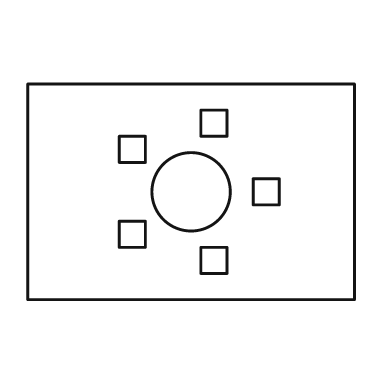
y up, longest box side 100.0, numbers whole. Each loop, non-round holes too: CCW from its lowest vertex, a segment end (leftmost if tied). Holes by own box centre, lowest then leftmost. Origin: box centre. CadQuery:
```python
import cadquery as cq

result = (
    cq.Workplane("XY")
    .moveTo(-50.0, -33.0)
    .lineTo(50.0, -33.0)
    .lineTo(50.0, 33.0)
    .lineTo(-50.0, 33.0)
    .close()
    .moveTo(3.0, -25.0)
    .lineTo(11.0, -25.0)
    .lineTo(11.0, -17.0)
    .lineTo(3.0, -17.0)
    .close()
    .moveTo(-22.0, -17.0)
    .lineTo(-14.0, -17.0)
    .lineTo(-14.0, -9.0)
    .lineTo(-22.0, -9.0)
    .close()
    .moveTo(0.0, 0.0)
    .circle(12.0)
    .moveTo(19.0, -4.0)
    .lineTo(27.0, -4.0)
    .lineTo(27.0, 4.0)
    .lineTo(19.0, 4.0)
    .close()
    .moveTo(-22.0, 9.0)
    .lineTo(-14.0, 9.0)
    .lineTo(-14.0, 17.0)
    .lineTo(-22.0, 17.0)
    .close()
    .moveTo(3.0, 17.0)
    .lineTo(11.0, 17.0)
    .lineTo(11.0, 25.0)
    .lineTo(3.0, 25.0)
    .close()
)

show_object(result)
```